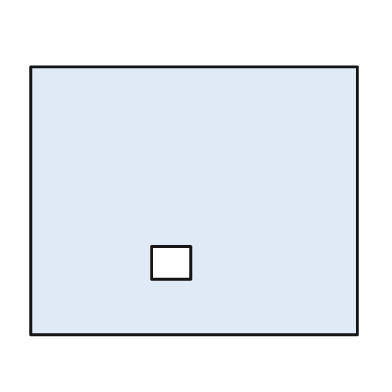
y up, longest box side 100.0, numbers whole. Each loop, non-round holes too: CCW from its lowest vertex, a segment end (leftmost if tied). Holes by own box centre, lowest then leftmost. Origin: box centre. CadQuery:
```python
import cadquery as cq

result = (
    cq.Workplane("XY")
    .moveTo(-50.0, -41.0)
    .lineTo(50.0, -41.0)
    .lineTo(50.0, 41.0)
    .lineTo(-50.0, 41.0)
    .close()
    .moveTo(-13.0, -24.0)
    .lineTo(-1.0, -24.0)
    .lineTo(-1.0, -14.0)
    .lineTo(-13.0, -14.0)
    .close()
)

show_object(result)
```